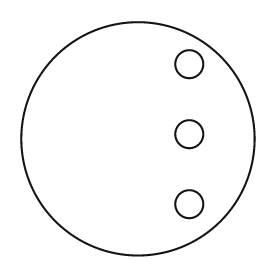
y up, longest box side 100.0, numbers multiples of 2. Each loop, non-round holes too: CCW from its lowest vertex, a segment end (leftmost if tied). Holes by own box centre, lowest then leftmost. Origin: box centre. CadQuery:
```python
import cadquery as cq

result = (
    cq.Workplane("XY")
    .moveTo(0.0, 0.0)
    .circle(50.0)
    .moveTo(22.0, -28.0)
    .circle(6.0)
    .moveTo(22.0, 2.0)
    .circle(6.0)
    .moveTo(22.0, 32.0)
    .circle(6.0)
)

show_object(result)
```